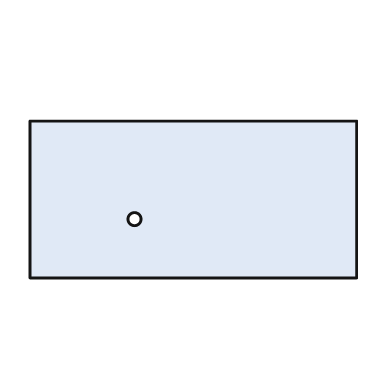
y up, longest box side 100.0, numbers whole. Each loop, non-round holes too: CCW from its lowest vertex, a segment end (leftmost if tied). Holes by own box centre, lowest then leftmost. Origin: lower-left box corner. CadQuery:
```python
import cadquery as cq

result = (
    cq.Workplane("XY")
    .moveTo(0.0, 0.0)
    .lineTo(100.0, 0.0)
    .lineTo(100.0, 48.0)
    .lineTo(0.0, 48.0)
    .close()
    .moveTo(32.0, 18.0)
    .circle(2.0)
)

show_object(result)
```